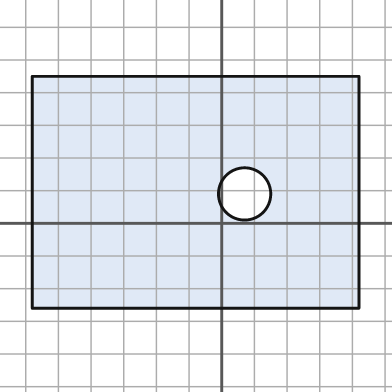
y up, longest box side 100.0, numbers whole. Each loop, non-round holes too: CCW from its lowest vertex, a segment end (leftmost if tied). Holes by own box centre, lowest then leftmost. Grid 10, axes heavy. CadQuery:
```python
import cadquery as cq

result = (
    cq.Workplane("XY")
    .moveTo(-58.0, -26.0)
    .lineTo(42.0, -26.0)
    .lineTo(42.0, 45.0)
    .lineTo(-58.0, 45.0)
    .close()
    .moveTo(7.0, 9.0)
    .circle(8.0)
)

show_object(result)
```